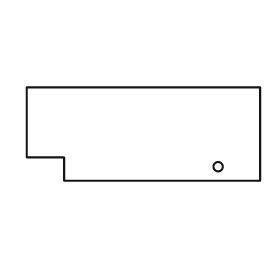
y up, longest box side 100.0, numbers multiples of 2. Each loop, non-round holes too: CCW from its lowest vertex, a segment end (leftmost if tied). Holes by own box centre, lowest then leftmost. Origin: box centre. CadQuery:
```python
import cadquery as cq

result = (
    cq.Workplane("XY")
    .moveTo(-34.0, -20.0)
    .lineTo(50.0, -20.0)
    .lineTo(50.0, 20.0)
    .lineTo(-50.0, 20.0)
    .lineTo(-50.0, -10.0)
    .lineTo(-34.0, -10.0)
    .close()
    .moveTo(32.0, -14.0)
    .circle(2.0)
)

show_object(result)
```